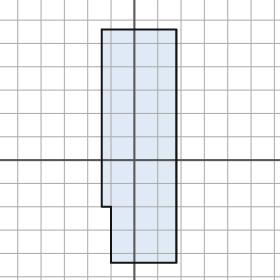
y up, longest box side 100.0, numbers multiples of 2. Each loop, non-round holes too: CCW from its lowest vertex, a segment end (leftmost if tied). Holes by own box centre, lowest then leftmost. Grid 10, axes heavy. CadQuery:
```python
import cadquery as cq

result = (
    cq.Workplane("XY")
    .moveTo(-10.0, -44.0)
    .lineTo(18.0, -44.0)
    .lineTo(18.0, 56.0)
    .lineTo(-14.0, 56.0)
    .lineTo(-14.0, -20.0)
    .lineTo(-10.0, -20.0)
    .close()
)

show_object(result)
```